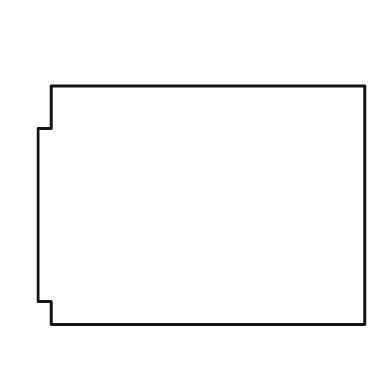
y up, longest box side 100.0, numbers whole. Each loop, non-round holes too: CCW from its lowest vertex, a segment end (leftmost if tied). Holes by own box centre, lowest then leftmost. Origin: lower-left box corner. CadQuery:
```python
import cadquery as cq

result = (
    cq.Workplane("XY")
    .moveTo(4.0, 0.0)
    .lineTo(100.0, 0.0)
    .lineTo(100.0, 73.0)
    .lineTo(4.0, 73.0)
    .lineTo(4.0, 60.0)
    .lineTo(0.0, 60.0)
    .lineTo(0.0, 7.0)
    .lineTo(4.0, 7.0)
    .close()
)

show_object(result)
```